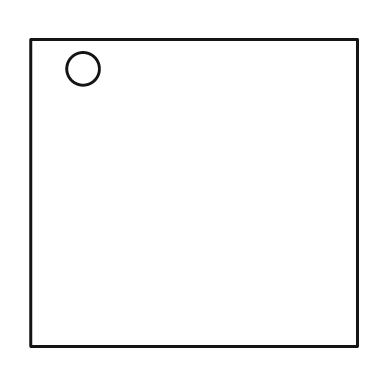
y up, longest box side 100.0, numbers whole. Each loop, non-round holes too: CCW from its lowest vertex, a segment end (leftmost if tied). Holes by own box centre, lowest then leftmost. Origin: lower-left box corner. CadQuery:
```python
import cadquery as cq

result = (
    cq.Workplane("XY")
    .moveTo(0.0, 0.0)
    .lineTo(100.0, 0.0)
    .lineTo(100.0, 94.0)
    .lineTo(0.0, 94.0)
    .close()
    .moveTo(16.0, 85.0)
    .circle(5.0)
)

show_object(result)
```